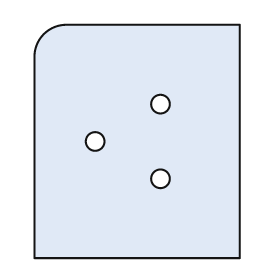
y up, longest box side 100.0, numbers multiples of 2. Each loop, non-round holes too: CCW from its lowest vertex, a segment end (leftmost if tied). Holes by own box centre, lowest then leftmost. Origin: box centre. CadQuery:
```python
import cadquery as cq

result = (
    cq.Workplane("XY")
    .moveTo(-44.0, -50.0)
    .lineTo(44.0, -50.0)
    .lineTo(44.0, 50.0)
    .lineTo(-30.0, 50.0)
    .threePointArc((-40.0, 46.0), (-44.0, 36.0))
    .close()
    .moveTo(10.0, -16.0)
    .circle(4.0)
    .moveTo(-18.0, 0.0)
    .circle(4.0)
    .moveTo(10.0, 16.0)
    .circle(4.0)
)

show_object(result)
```